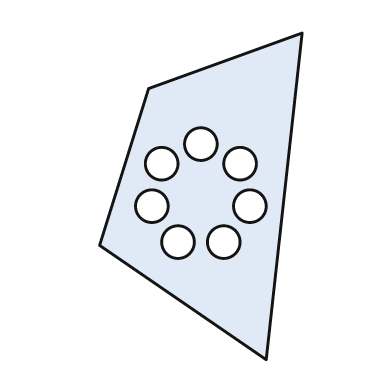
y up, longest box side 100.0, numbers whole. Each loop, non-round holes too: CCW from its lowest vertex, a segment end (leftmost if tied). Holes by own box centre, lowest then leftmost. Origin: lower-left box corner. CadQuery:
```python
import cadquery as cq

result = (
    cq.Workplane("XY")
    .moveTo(51.0, 0.0)
    .lineTo(62.0, 100.0)
    .lineTo(15.0, 83.0)
    .lineTo(0.0, 35.0)
    .close()
    .moveTo(24.0, 36.0)
    .circle(5.0)
    .moveTo(38.0, 36.0)
    .circle(5.0)
    .moveTo(16.0, 47.0)
    .circle(5.0)
    .moveTo(46.0, 47.0)
    .circle(5.0)
    .moveTo(19.0, 60.0)
    .circle(5.0)
    .moveTo(43.0, 60.0)
    .circle(5.0)
    .moveTo(31.0, 66.0)
    .circle(5.0)
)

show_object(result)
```